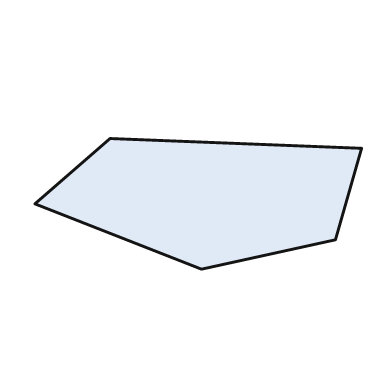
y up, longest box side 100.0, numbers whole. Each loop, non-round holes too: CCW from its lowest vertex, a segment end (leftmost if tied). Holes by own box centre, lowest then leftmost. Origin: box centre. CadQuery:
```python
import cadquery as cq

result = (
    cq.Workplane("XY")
    .moveTo(1.0, -20.0)
    .lineTo(42.0, -11.0)
    .lineTo(50.0, 17.0)
    .lineTo(-27.0, 20.0)
    .lineTo(-50.0, 0.0)
    .close()
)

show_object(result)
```